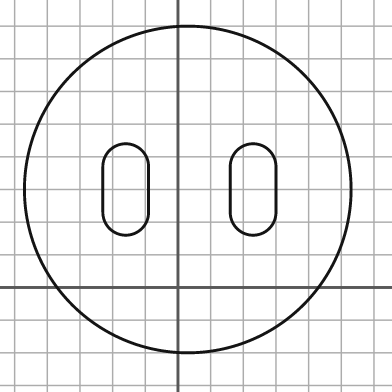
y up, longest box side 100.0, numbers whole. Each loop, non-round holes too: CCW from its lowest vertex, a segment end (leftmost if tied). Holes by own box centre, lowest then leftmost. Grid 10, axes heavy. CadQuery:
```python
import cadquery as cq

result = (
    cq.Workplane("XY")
    .moveTo(3.0, 30.0)
    .circle(50.0)
    .moveTo(-23.0, 23.0)
    .threePointArc((-16.0, 16.0), (-9.0, 23.0))
    .lineTo(-9.0, 37.0)
    .threePointArc((-16.0, 44.0), (-23.0, 37.0))
    .close()
    .moveTo(16.0, 23.0)
    .threePointArc((23.0, 16.0), (30.0, 23.0))
    .lineTo(30.0, 37.0)
    .threePointArc((23.0, 44.0), (16.0, 37.0))
    .close()
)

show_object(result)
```